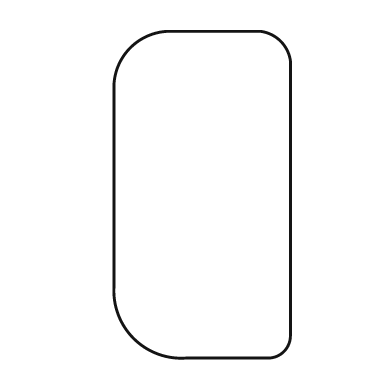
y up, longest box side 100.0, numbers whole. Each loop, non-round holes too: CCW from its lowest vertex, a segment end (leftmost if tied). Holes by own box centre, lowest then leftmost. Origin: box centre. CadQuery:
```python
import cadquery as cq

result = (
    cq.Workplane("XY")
    .moveTo(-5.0, -50.0)
    .lineTo(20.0, -50.0)
    .threePointArc((25.0, -48.0), (27.0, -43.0))
    .lineTo(27.0, 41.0)
    .threePointArc((24.0, 47.0), (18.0, 50.0))
    .lineTo(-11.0, 50.0)
    .threePointArc((-22.0, 45.0), (-27.0, 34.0))
    .lineTo(-27.0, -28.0)
    .threePointArc((-21.0, -44.0), (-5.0, -50.0))
    .close()
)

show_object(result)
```